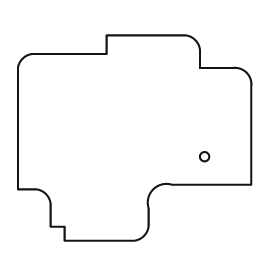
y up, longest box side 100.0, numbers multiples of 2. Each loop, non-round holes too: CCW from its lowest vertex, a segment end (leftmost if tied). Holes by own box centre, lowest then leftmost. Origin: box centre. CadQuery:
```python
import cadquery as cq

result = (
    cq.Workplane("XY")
    .moveTo(-30.0, -44.0)
    .lineTo(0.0, -44.0)
    .threePointArc((4.0, -42.0), (6.0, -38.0))
    .lineTo(6.0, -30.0)
    .threePointArc((8.0, -22.0), (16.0, -20.0))
    .lineTo(50.0, -20.0)
    .lineTo(50.0, 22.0)
    .threePointArc((48.0, 28.0), (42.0, 30.0))
    .lineTo(28.0, 30.0)
    .lineTo(28.0, 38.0)
    .threePointArc((26.0, 42.0), (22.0, 44.0))
    .lineTo(-12.0, 44.0)
    .lineTo(-12.0, 36.0)
    .lineTo(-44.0, 36.0)
    .threePointArc((-48.0, 34.0), (-50.0, 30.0))
    .lineTo(-50.0, -22.0)
    .lineTo(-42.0, -22.0)
    .threePointArc((-38.0, -24.0), (-36.0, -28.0))
    .lineTo(-36.0, -38.0)
    .lineTo(-30.0, -38.0)
    .close()
    .moveTo(30.0, -8.0)
    .circle(2.0)
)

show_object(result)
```